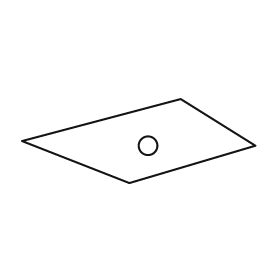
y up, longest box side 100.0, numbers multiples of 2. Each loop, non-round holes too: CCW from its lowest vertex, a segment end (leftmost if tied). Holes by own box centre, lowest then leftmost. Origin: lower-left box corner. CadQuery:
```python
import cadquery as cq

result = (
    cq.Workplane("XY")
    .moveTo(46.0, 0.0)
    .lineTo(100.0, 16.0)
    .lineTo(68.0, 36.0)
    .lineTo(0.0, 18.0)
    .close()
    .moveTo(54.0, 16.0)
    .circle(4.0)
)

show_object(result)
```